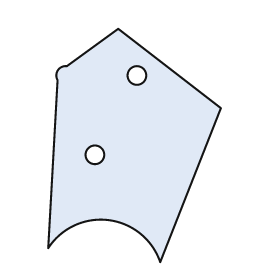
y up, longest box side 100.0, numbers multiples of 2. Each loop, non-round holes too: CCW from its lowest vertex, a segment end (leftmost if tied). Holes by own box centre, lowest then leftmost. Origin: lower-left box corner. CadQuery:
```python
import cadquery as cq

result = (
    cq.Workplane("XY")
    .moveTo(48.0, 0.0)
    .lineTo(74.0, 66.0)
    .lineTo(30.0, 100.0)
    .lineTo(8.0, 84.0)
    .threePointArc((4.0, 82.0), (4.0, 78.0))
    .lineTo(0.0, 6.0)
    .threePointArc((26.0, 18.0), (48.0, 0.0))
    .close()
    .moveTo(20.0, 46.0)
    .circle(4.0)
    .moveTo(38.0, 80.0)
    .circle(4.0)
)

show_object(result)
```